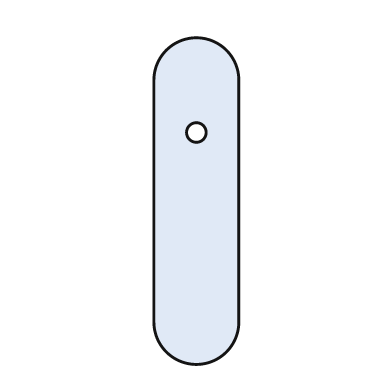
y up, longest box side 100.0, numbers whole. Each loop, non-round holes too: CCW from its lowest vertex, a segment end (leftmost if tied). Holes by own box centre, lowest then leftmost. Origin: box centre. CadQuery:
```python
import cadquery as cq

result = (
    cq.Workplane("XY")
    .moveTo(-13.0, -37.0)
    .threePointArc((0.0, -50.0), (13.0, -37.0))
    .lineTo(13.0, 37.0)
    .threePointArc((0.0, 50.0), (-13.0, 37.0))
    .close()
    .moveTo(0.0, 21.0)
    .circle(3.0)
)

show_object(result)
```